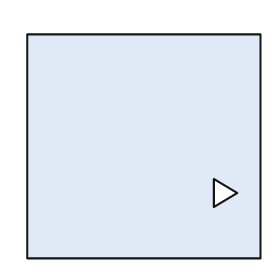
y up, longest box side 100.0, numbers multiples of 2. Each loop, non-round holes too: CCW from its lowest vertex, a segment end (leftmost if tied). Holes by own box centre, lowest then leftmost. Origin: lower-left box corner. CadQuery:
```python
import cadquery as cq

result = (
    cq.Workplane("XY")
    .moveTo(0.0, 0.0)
    .lineTo(100.0, 0.0)
    .lineTo(100.0, 96.0)
    .lineTo(0.0, 96.0)
    .close()
    .moveTo(80.0, 22.0)
    .lineTo(90.0, 28.0)
    .lineTo(80.0, 34.0)
    .close()
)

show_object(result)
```